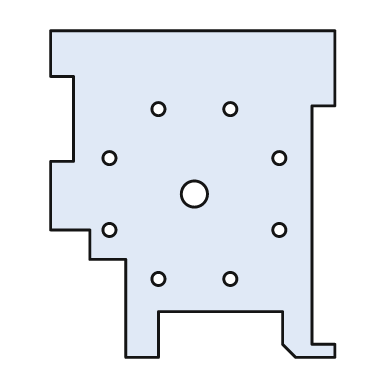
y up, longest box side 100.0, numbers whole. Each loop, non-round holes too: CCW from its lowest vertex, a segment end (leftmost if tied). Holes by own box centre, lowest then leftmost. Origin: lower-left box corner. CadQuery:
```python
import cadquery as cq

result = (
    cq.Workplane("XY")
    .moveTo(23.0, 0.0)
    .lineTo(33.0, 0.0)
    .lineTo(33.0, 14.0)
    .lineTo(71.0, 14.0)
    .lineTo(71.0, 4.0)
    .lineTo(75.0, 0.0)
    .lineTo(87.0, 0.0)
    .lineTo(87.0, 4.0)
    .lineTo(80.0, 4.0)
    .lineTo(80.0, 77.0)
    .lineTo(87.0, 77.0)
    .lineTo(87.0, 100.0)
    .lineTo(0.0, 100.0)
    .lineTo(0.0, 86.0)
    .lineTo(7.0, 86.0)
    .lineTo(7.0, 60.0)
    .lineTo(0.0, 60.0)
    .lineTo(0.0, 39.0)
    .lineTo(12.0, 39.0)
    .lineTo(12.0, 30.0)
    .lineTo(23.0, 30.0)
    .close()
    .moveTo(33.0, 24.0)
    .circle(2.0)
    .moveTo(55.0, 24.0)
    .circle(2.0)
    .moveTo(18.0, 39.0)
    .circle(2.0)
    .moveTo(70.0, 39.0)
    .circle(2.0)
    .moveTo(44.0, 50.0)
    .circle(4.0)
    .moveTo(18.0, 61.0)
    .circle(2.0)
    .moveTo(70.0, 61.0)
    .circle(2.0)
    .moveTo(33.0, 76.0)
    .circle(2.0)
    .moveTo(55.0, 76.0)
    .circle(2.0)
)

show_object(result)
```